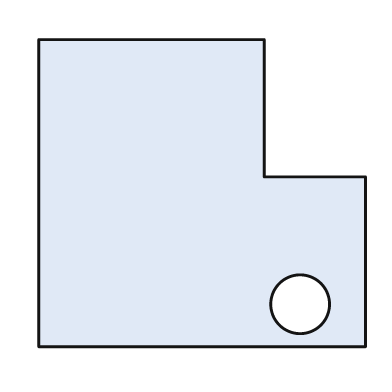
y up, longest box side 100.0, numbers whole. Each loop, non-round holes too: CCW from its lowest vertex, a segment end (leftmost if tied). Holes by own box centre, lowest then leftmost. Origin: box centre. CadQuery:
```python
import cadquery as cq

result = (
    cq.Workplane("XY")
    .moveTo(-50.0, -47.0)
    .lineTo(50.0, -47.0)
    .lineTo(50.0, 5.0)
    .lineTo(19.0, 5.0)
    .lineTo(19.0, 47.0)
    .lineTo(-50.0, 47.0)
    .close()
    .moveTo(30.0, -34.0)
    .circle(9.0)
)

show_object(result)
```